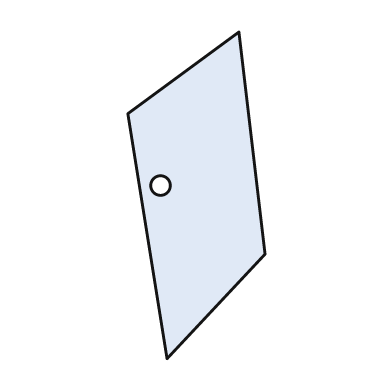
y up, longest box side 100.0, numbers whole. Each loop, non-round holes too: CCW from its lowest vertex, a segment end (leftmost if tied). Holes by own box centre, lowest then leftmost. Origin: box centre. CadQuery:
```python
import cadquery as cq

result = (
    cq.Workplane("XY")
    .moveTo(-9.0, -50.0)
    .lineTo(21.0, -18.0)
    .lineTo(13.0, 50.0)
    .lineTo(-21.0, 25.0)
    .close()
    .moveTo(-11.0, 3.0)
    .circle(3.0)
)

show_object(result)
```